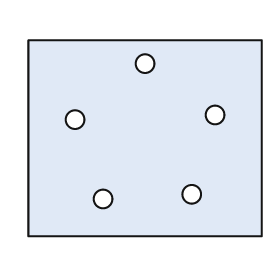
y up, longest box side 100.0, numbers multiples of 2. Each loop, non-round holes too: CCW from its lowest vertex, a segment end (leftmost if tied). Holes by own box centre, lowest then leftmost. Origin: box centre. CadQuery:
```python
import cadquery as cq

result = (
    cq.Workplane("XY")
    .moveTo(-50.0, -42.0)
    .lineTo(50.0, -42.0)
    .lineTo(50.0, 42.0)
    .lineTo(-50.0, 42.0)
    .close()
    .moveTo(-18.0, -26.0)
    .circle(4.0)
    .moveTo(20.0, -24.0)
    .circle(4.0)
    .moveTo(-30.0, 8.0)
    .circle(4.0)
    .moveTo(30.0, 10.0)
    .circle(4.0)
    .moveTo(0.0, 32.0)
    .circle(4.0)
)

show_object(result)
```